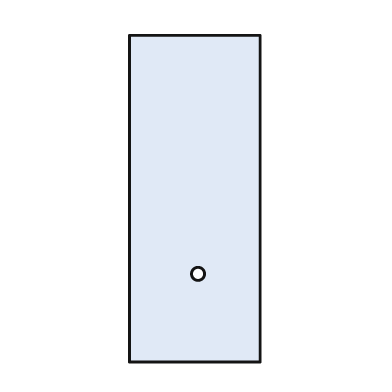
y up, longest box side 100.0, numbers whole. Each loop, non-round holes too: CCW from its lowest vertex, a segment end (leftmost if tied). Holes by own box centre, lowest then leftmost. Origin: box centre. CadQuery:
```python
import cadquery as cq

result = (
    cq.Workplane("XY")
    .moveTo(-20.0, -50.0)
    .lineTo(20.0, -50.0)
    .lineTo(20.0, 50.0)
    .lineTo(-20.0, 50.0)
    .close()
    .moveTo(1.0, -23.0)
    .circle(2.0)
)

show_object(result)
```